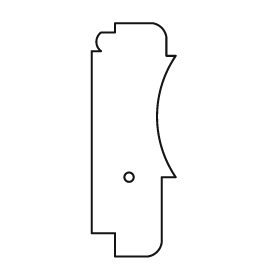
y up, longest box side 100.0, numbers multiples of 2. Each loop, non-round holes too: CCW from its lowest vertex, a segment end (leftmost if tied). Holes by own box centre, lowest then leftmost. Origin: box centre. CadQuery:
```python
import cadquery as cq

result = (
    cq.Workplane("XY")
    .moveTo(-8.0, -50.0)
    .lineTo(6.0, -50.0)
    .threePointArc((10.0, -48.0), (12.0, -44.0))
    .lineTo(12.0, -16.0)
    .lineTo(18.0, -16.0)
    .threePointArc((10.0, 10.0), (18.0, 36.0))
    .lineTo(14.0, 36.0)
    .lineTo(14.0, 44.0)
    .threePointArc((12.0, 48.0), (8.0, 50.0))
    .lineTo(-8.0, 50.0)
    .lineTo(-8.0, 46.0)
    .lineTo(-14.0, 46.0)
    .threePointArc((-16.0, 42.0), (-14.0, 38.0))
    .lineTo(-18.0, 38.0)
    .lineTo(-18.0, -40.0)
    .lineTo(-8.0, -40.0)
    .close()
    .moveTo(-2.0, -16.0)
    .circle(2.0)
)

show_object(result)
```